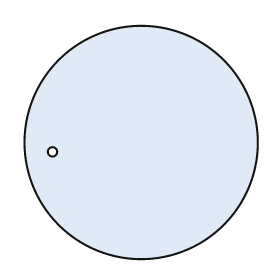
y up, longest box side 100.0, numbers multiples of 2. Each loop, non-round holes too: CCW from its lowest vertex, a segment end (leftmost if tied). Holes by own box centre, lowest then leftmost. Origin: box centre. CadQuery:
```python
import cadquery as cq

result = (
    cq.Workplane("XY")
    .moveTo(0.0, 0.0)
    .circle(50.0)
    .moveTo(-38.0, -4.0)
    .circle(2.0)
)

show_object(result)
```